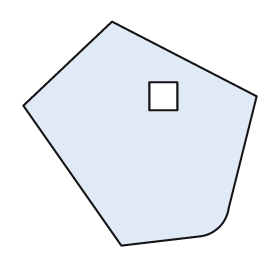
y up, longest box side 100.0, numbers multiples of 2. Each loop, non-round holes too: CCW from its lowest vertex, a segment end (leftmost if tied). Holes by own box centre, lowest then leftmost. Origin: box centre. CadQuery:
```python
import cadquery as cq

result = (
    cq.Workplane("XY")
    .moveTo(-8.0, -48.0)
    .lineTo(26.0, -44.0)
    .threePointArc((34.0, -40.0), (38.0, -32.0))
    .lineTo(50.0, 16.0)
    .lineTo(-12.0, 48.0)
    .lineTo(-50.0, 12.0)
    .close()
    .moveTo(4.0, 10.0)
    .lineTo(16.0, 10.0)
    .lineTo(16.0, 22.0)
    .lineTo(4.0, 22.0)
    .close()
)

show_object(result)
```